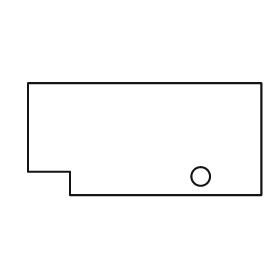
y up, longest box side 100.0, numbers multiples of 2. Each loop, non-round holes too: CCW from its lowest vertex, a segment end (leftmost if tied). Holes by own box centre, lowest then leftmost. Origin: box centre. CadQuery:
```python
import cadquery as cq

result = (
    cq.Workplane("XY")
    .moveTo(-32.0, -24.0)
    .lineTo(50.0, -24.0)
    .lineTo(50.0, 24.0)
    .lineTo(-50.0, 24.0)
    .lineTo(-50.0, -14.0)
    .lineTo(-32.0, -14.0)
    .close()
    .moveTo(24.0, -16.0)
    .circle(4.0)
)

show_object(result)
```